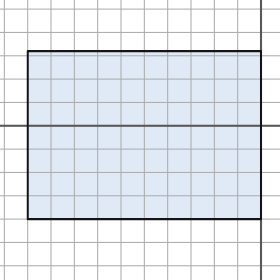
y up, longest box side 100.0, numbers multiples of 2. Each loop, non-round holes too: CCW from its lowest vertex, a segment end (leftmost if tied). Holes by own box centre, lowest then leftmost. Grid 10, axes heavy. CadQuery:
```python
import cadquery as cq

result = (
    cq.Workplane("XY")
    .moveTo(-100.0, -40.0)
    .lineTo(0.0, -40.0)
    .lineTo(0.0, 32.0)
    .lineTo(-100.0, 32.0)
    .close()
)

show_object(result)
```